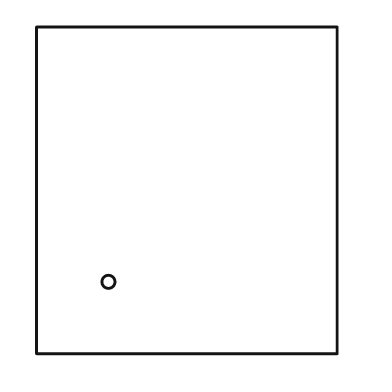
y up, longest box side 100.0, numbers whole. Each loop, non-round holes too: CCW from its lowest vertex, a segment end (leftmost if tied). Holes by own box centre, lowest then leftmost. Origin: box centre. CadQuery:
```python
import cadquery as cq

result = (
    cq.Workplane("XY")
    .moveTo(-46.0, -50.0)
    .lineTo(46.0, -50.0)
    .lineTo(46.0, 50.0)
    .lineTo(-46.0, 50.0)
    .close()
    .moveTo(-24.0, -28.0)
    .circle(2.0)
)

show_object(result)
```